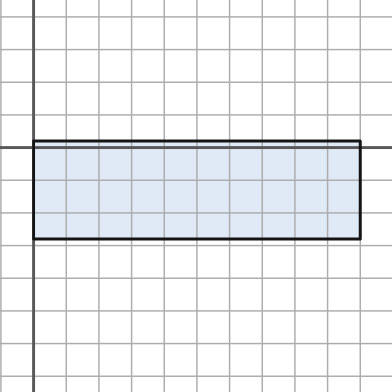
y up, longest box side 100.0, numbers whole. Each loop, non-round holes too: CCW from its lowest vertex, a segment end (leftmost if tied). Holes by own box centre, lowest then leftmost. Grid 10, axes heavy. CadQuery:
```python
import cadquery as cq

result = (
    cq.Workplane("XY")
    .moveTo(0.0, -28.0)
    .lineTo(100.0, -28.0)
    .lineTo(100.0, 2.0)
    .lineTo(0.0, 2.0)
    .close()
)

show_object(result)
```